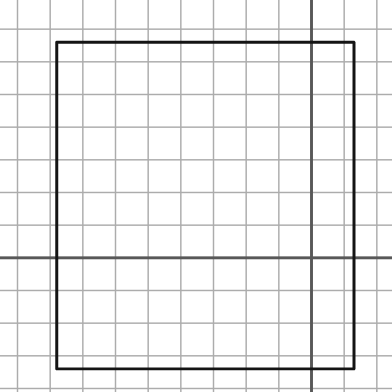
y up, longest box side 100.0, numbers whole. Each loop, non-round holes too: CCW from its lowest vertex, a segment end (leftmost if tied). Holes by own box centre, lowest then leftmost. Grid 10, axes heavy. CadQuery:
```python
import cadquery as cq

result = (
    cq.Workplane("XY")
    .moveTo(-78.0, -34.0)
    .lineTo(13.0, -34.0)
    .lineTo(13.0, 66.0)
    .lineTo(-78.0, 66.0)
    .close()
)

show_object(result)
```